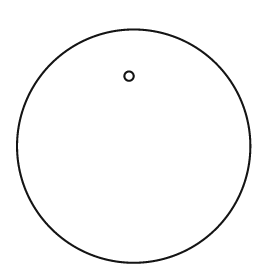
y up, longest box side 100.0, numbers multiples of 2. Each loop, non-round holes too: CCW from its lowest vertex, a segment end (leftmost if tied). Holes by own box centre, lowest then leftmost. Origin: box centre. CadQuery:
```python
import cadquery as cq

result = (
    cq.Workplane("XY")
    .moveTo(0.0, 0.0)
    .circle(50.0)
    .moveTo(-2.0, 30.0)
    .circle(2.0)
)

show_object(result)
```